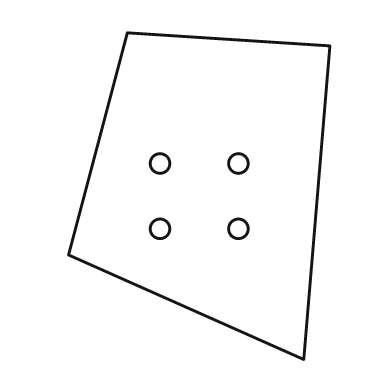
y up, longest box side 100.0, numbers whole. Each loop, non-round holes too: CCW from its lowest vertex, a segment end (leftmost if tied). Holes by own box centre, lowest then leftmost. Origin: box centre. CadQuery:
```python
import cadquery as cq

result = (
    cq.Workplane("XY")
    .moveTo(32.0, -50.0)
    .lineTo(40.0, 46.0)
    .lineTo(-22.0, 50.0)
    .lineTo(-40.0, -18.0)
    .close()
    .moveTo(-12.0, -10.0)
    .circle(3.0)
    .moveTo(12.0, -10.0)
    .circle(3.0)
    .moveTo(-12.0, 10.0)
    .circle(3.0)
    .moveTo(12.0, 10.0)
    .circle(3.0)
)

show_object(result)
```